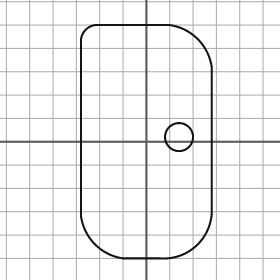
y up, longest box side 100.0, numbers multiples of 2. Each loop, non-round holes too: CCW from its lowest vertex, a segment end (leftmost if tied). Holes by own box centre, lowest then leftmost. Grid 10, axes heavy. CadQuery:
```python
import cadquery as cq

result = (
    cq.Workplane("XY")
    .moveTo(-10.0, -50.0)
    .lineTo(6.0, -50.0)
    .threePointArc((22.0, -44.0), (28.0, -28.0))
    .lineTo(28.0, 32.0)
    .threePointArc((22.0, 44.0), (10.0, 50.0))
    .lineTo(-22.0, 50.0)
    .threePointArc((-26.0, 48.0), (-28.0, 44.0))
    .lineTo(-28.0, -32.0)
    .threePointArc((-22.0, -44.0), (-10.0, -50.0))
    .close()
    .moveTo(14.0, 2.0)
    .circle(6.0)
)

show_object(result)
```